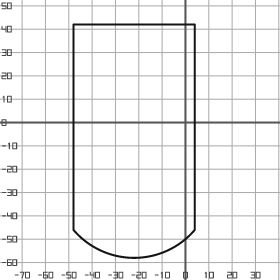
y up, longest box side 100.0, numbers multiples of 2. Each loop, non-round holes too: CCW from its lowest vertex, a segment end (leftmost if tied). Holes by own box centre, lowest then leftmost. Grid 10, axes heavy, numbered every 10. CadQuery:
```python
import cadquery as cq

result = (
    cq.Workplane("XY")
    .moveTo(-48.0, -46.0)
    .threePointArc((-22.0, -58.0), (4.0, -46.0))
    .lineTo(4.0, 42.0)
    .lineTo(-48.0, 42.0)
    .close()
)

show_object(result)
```